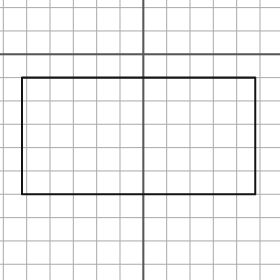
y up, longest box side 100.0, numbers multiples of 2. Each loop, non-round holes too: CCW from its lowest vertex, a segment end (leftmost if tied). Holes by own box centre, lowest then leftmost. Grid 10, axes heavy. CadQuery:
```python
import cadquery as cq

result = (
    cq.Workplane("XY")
    .moveTo(-52.0, -60.0)
    .lineTo(48.0, -60.0)
    .lineTo(48.0, -10.0)
    .lineTo(-52.0, -10.0)
    .close()
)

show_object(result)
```